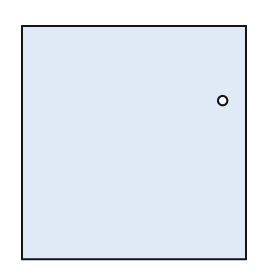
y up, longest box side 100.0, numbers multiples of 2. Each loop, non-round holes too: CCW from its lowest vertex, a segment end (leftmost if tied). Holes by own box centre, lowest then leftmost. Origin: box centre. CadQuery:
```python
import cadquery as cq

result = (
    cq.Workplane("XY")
    .moveTo(-48.0, -50.0)
    .lineTo(48.0, -50.0)
    .lineTo(48.0, 50.0)
    .lineTo(-48.0, 50.0)
    .close()
    .moveTo(38.0, 18.0)
    .circle(2.0)
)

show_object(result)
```